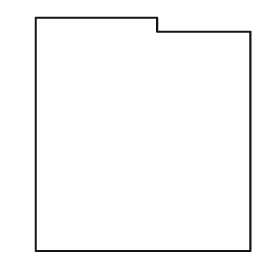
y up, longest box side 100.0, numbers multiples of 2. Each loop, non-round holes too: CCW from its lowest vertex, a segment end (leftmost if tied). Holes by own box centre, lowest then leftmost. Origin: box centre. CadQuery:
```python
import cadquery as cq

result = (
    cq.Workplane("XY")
    .moveTo(-46.0, -50.0)
    .lineTo(46.0, -50.0)
    .lineTo(46.0, 44.0)
    .lineTo(6.0, 44.0)
    .lineTo(6.0, 50.0)
    .lineTo(-46.0, 50.0)
    .close()
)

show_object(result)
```